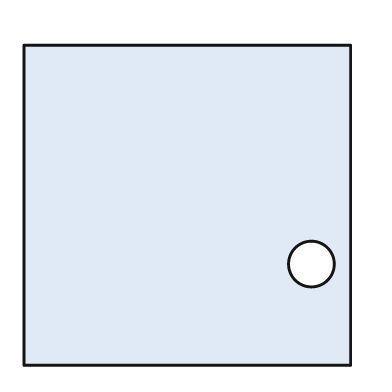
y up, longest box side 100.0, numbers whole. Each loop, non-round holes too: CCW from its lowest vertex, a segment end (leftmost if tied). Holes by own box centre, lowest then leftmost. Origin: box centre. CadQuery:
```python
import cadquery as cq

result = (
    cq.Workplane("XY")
    .moveTo(-50.0, -49.0)
    .lineTo(50.0, -49.0)
    .lineTo(50.0, 49.0)
    .lineTo(-50.0, 49.0)
    .close()
    .moveTo(38.0, -18.0)
    .circle(7.0)
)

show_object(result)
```